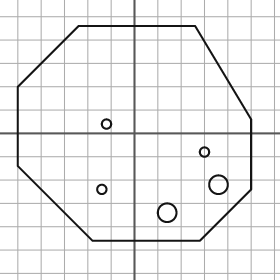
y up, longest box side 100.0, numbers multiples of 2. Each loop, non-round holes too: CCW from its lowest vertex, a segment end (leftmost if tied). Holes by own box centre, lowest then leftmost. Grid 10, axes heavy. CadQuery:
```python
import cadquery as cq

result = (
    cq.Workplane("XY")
    .moveTo(-18.0, -46.0)
    .lineTo(28.0, -46.0)
    .lineTo(50.0, -24.0)
    .lineTo(50.0, 6.0)
    .lineTo(26.0, 46.0)
    .lineTo(-24.0, 46.0)
    .lineTo(-50.0, 20.0)
    .lineTo(-50.0, -14.0)
    .close()
    .moveTo(14.0, -34.0)
    .circle(4.0)
    .moveTo(-14.0, -24.0)
    .circle(2.0)
    .moveTo(36.0, -22.0)
    .circle(4.0)
    .moveTo(30.0, -8.0)
    .circle(2.0)
    .moveTo(-12.0, 4.0)
    .circle(2.0)
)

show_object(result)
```